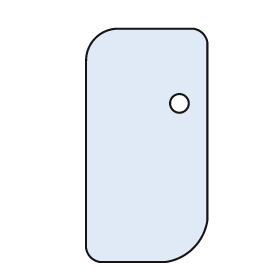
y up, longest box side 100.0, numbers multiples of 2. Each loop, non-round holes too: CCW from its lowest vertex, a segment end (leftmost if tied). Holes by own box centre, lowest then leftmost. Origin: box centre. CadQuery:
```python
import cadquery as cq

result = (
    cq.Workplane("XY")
    .moveTo(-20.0, -50.0)
    .lineTo(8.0, -50.0)
    .threePointArc((20.0, -44.0), (26.0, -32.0))
    .lineTo(26.0, 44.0)
    .threePointArc((24.0, 48.0), (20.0, 50.0))
    .lineTo(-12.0, 50.0)
    .threePointArc((-22.0, 46.0), (-26.0, 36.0))
    .lineTo(-26.0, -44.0)
    .threePointArc((-24.0, -48.0), (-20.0, -50.0))
    .close()
    .moveTo(14.0, 18.0)
    .circle(4.0)
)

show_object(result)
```